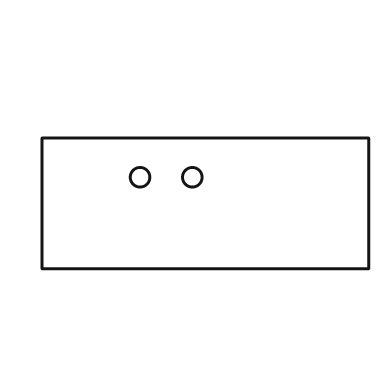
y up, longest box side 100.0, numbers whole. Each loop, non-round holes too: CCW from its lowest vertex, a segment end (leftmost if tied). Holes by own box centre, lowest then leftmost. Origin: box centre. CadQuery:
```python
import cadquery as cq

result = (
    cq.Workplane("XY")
    .moveTo(-50.0, -20.0)
    .lineTo(50.0, -20.0)
    .lineTo(50.0, 20.0)
    .lineTo(-50.0, 20.0)
    .close()
    .moveTo(-20.0, 8.0)
    .circle(3.0)
    .moveTo(-4.0, 8.0)
    .circle(3.0)
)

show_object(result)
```